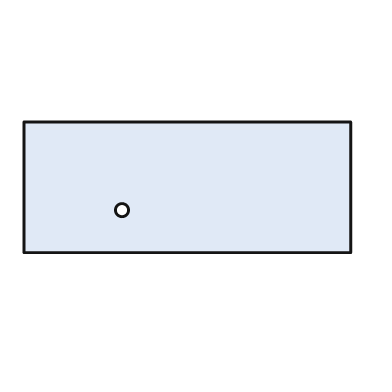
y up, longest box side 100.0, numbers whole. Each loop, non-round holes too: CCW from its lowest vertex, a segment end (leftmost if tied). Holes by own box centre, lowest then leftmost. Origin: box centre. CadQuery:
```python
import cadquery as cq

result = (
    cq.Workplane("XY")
    .moveTo(-50.0, -20.0)
    .lineTo(50.0, -20.0)
    .lineTo(50.0, 20.0)
    .lineTo(-50.0, 20.0)
    .close()
    .moveTo(-20.0, -7.0)
    .circle(2.0)
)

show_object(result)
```